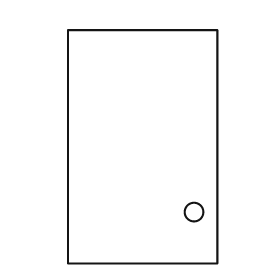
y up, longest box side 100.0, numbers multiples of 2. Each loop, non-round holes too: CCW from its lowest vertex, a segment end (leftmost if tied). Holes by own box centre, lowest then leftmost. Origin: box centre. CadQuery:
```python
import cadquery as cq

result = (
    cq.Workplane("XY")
    .moveTo(-32.0, -50.0)
    .lineTo(32.0, -50.0)
    .lineTo(32.0, 50.0)
    .lineTo(-32.0, 50.0)
    .close()
    .moveTo(22.0, -28.0)
    .circle(4.0)
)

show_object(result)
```